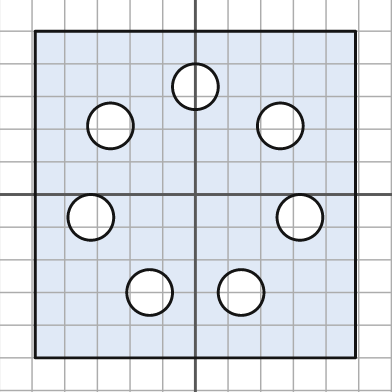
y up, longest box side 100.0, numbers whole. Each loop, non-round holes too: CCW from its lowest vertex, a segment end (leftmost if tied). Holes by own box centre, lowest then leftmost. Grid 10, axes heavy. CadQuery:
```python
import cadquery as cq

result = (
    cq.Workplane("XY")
    .moveTo(-49.0, -50.0)
    .lineTo(49.0, -50.0)
    .lineTo(49.0, 50.0)
    .lineTo(-49.0, 50.0)
    .close()
    .moveTo(-14.0, -30.0)
    .circle(7.0)
    .moveTo(14.0, -30.0)
    .circle(7.0)
    .moveTo(-32.0, -7.0)
    .circle(7.0)
    .moveTo(32.0, -7.0)
    .circle(7.0)
    .moveTo(-26.0, 21.0)
    .circle(7.0)
    .moveTo(26.0, 21.0)
    .circle(7.0)
    .moveTo(0.0, 33.0)
    .circle(7.0)
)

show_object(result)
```